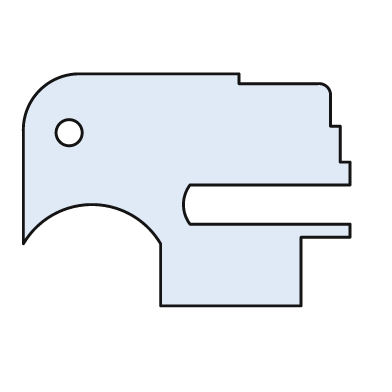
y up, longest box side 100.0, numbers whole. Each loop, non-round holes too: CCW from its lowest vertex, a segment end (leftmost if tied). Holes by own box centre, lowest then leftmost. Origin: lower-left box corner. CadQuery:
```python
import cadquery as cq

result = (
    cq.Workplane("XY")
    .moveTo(42.0, 0.0)
    .lineTo(85.0, 0.0)
    .lineTo(85.0, 21.0)
    .lineTo(100.0, 21.0)
    .lineTo(100.0, 25.0)
    .lineTo(51.0, 25.0)
    .threePointArc((49.0, 31.0), (51.0, 37.0))
    .lineTo(100.0, 37.0)
    .lineTo(100.0, 44.0)
    .lineTo(97.0, 44.0)
    .lineTo(97.0, 55.0)
    .lineTo(94.0, 55.0)
    .lineTo(94.0, 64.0)
    .threePointArc((93.0, 67.0), (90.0, 68.0))
    .lineTo(66.0, 68.0)
    .lineTo(66.0, 71.0)
    .lineTo(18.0, 71.0)
    .threePointArc((5.0, 66.0), (0.0, 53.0))
    .lineTo(0.0, 19.0)
    .threePointArc((21.0, 31.0), (42.0, 19.0))
    .close()
    .moveTo(14.0, 53.0)
    .circle(4.0)
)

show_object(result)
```